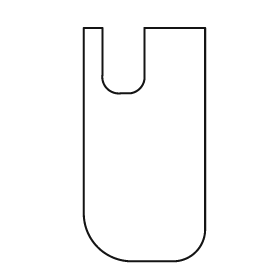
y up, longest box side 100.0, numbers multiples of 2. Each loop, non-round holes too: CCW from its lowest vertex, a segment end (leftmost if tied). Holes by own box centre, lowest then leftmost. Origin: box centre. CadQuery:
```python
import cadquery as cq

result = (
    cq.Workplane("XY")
    .moveTo(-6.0, -50.0)
    .lineTo(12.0, -50.0)
    .threePointArc((22.0, -46.0), (26.0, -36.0))
    .lineTo(26.0, 50.0)
    .lineTo(0.0, 50.0)
    .lineTo(0.0, 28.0)
    .threePointArc((-2.0, 24.0), (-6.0, 22.0))
    .lineTo(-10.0, 22.0)
    .threePointArc((-16.0, 24.0), (-18.0, 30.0))
    .lineTo(-18.0, 50.0)
    .lineTo(-26.0, 50.0)
    .lineTo(-26.0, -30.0)
    .threePointArc((-20.0, -44.0), (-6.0, -50.0))
    .close()
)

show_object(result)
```